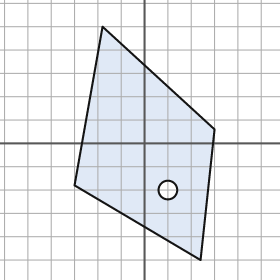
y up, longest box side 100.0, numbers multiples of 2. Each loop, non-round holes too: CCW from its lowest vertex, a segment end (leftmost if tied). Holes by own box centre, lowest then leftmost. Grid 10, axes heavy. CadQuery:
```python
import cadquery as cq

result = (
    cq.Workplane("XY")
    .moveTo(24.0, -50.0)
    .lineTo(30.0, 6.0)
    .lineTo(-18.0, 50.0)
    .lineTo(-30.0, -18.0)
    .close()
    .moveTo(10.0, -20.0)
    .circle(4.0)
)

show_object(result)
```